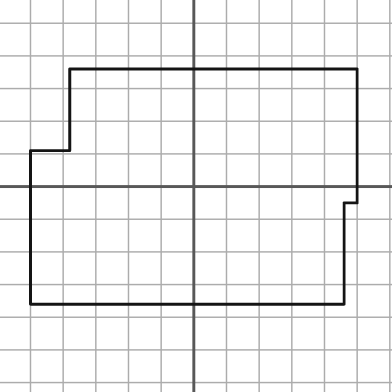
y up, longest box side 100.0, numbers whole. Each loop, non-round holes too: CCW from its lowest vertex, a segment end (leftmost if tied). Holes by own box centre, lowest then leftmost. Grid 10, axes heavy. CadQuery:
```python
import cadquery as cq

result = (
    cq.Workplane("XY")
    .moveTo(-50.0, -36.0)
    .lineTo(46.0, -36.0)
    .lineTo(46.0, -5.0)
    .lineTo(50.0, -5.0)
    .lineTo(50.0, 36.0)
    .lineTo(-38.0, 36.0)
    .lineTo(-38.0, 11.0)
    .lineTo(-50.0, 11.0)
    .close()
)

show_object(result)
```